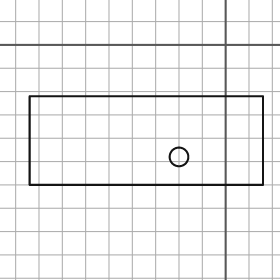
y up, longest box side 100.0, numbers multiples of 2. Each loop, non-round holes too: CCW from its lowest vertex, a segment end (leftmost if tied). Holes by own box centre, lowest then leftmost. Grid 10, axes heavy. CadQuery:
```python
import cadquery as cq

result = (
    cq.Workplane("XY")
    .moveTo(-84.0, -60.0)
    .lineTo(16.0, -60.0)
    .lineTo(16.0, -22.0)
    .lineTo(-84.0, -22.0)
    .close()
    .moveTo(-20.0, -48.0)
    .circle(4.0)
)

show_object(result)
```